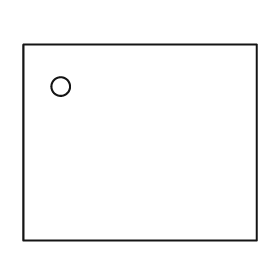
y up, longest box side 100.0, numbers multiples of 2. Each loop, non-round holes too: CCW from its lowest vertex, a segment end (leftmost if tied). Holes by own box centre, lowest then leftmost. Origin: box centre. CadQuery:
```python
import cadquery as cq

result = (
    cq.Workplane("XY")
    .moveTo(-50.0, -42.0)
    .lineTo(50.0, -42.0)
    .lineTo(50.0, 42.0)
    .lineTo(-50.0, 42.0)
    .close()
    .moveTo(-34.0, 24.0)
    .circle(4.0)
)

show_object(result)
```